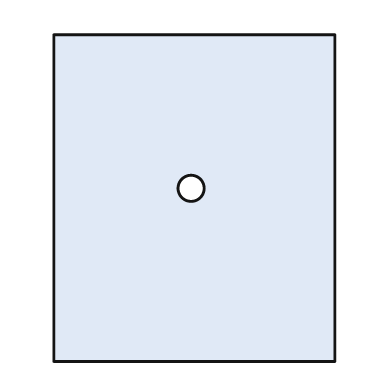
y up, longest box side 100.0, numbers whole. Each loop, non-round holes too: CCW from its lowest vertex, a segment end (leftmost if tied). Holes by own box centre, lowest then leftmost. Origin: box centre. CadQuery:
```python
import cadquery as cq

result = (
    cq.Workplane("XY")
    .moveTo(-43.0, -50.0)
    .lineTo(43.0, -50.0)
    .lineTo(43.0, 50.0)
    .lineTo(-43.0, 50.0)
    .close()
    .moveTo(-1.0, 3.0)
    .circle(4.0)
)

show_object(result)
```